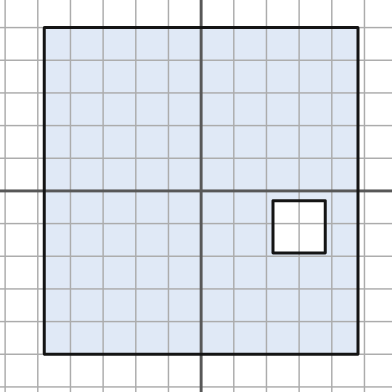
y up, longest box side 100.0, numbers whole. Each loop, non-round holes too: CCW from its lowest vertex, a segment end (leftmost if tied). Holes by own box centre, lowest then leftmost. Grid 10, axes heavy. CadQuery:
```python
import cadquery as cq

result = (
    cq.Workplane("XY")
    .moveTo(-48.0, -50.0)
    .lineTo(48.0, -50.0)
    .lineTo(48.0, 50.0)
    .lineTo(-48.0, 50.0)
    .close()
    .moveTo(22.0, -19.0)
    .lineTo(38.0, -19.0)
    .lineTo(38.0, -3.0)
    .lineTo(22.0, -3.0)
    .close()
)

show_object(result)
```